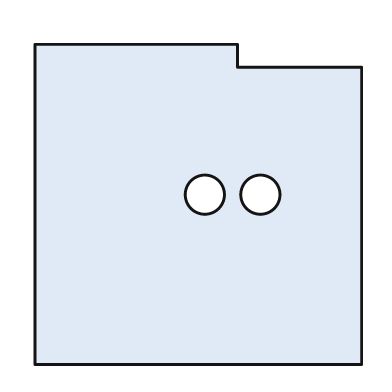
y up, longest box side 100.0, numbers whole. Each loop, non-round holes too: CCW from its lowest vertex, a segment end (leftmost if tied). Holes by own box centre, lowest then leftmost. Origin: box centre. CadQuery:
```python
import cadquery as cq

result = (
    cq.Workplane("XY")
    .moveTo(-50.0, -49.0)
    .lineTo(50.0, -49.0)
    .lineTo(50.0, 42.0)
    .lineTo(12.0, 42.0)
    .lineTo(12.0, 49.0)
    .lineTo(-50.0, 49.0)
    .close()
    .moveTo(2.0, 3.0)
    .circle(6.0)
    .moveTo(19.0, 3.0)
    .circle(6.0)
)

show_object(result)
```